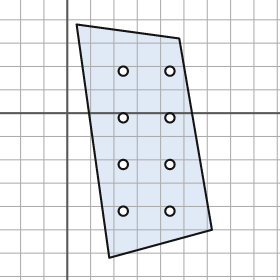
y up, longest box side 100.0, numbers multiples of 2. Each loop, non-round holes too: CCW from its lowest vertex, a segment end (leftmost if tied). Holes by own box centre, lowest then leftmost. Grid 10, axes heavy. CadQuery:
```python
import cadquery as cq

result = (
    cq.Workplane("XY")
    .moveTo(18.0, -62.0)
    .lineTo(62.0, -50.0)
    .lineTo(48.0, 32.0)
    .lineTo(4.0, 38.0)
    .close()
    .moveTo(24.0, -42.0)
    .circle(2.0)
    .moveTo(44.0, -42.0)
    .circle(2.0)
    .moveTo(24.0, -22.0)
    .circle(2.0)
    .moveTo(44.0, -22.0)
    .circle(2.0)
    .moveTo(24.0, -2.0)
    .circle(2.0)
    .moveTo(44.0, -2.0)
    .circle(2.0)
    .moveTo(24.0, 18.0)
    .circle(2.0)
    .moveTo(44.0, 18.0)
    .circle(2.0)
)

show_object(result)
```